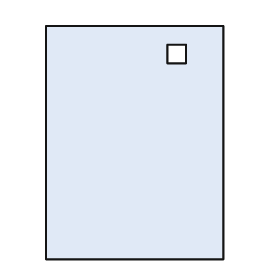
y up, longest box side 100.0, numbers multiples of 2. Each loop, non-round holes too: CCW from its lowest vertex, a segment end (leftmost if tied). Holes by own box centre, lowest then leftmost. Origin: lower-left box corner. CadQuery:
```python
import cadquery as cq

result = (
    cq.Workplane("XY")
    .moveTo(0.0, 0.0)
    .lineTo(76.0, 0.0)
    .lineTo(76.0, 100.0)
    .lineTo(0.0, 100.0)
    .close()
    .moveTo(52.0, 84.0)
    .lineTo(60.0, 84.0)
    .lineTo(60.0, 92.0)
    .lineTo(52.0, 92.0)
    .close()
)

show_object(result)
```